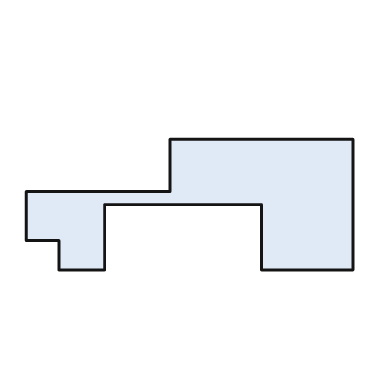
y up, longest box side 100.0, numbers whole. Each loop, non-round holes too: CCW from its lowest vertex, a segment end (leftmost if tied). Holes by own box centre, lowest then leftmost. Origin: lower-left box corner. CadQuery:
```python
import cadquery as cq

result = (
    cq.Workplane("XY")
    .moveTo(10.0, 0.0)
    .lineTo(24.0, 0.0)
    .lineTo(24.0, 20.0)
    .lineTo(72.0, 20.0)
    .lineTo(72.0, 0.0)
    .lineTo(100.0, 0.0)
    .lineTo(100.0, 40.0)
    .lineTo(44.0, 40.0)
    .lineTo(44.0, 24.0)
    .lineTo(0.0, 24.0)
    .lineTo(0.0, 9.0)
    .lineTo(10.0, 9.0)
    .close()
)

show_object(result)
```